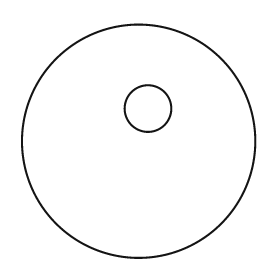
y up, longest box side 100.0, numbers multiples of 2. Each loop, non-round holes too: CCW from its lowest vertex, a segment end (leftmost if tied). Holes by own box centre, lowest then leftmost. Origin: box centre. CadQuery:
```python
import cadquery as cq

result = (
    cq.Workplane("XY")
    .moveTo(0.0, 0.0)
    .circle(50.0)
    .moveTo(4.0, 14.0)
    .circle(10.0)
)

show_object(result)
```